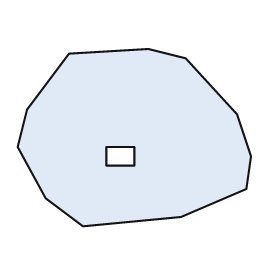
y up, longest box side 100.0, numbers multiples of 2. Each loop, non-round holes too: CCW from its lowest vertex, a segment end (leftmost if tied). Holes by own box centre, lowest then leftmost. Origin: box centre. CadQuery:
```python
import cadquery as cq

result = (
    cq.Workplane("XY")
    .moveTo(-22.0, -38.0)
    .lineTo(20.0, -34.0)
    .lineTo(48.0, -22.0)
    .lineTo(50.0, -8.0)
    .lineTo(44.0, 10.0)
    .lineTo(22.0, 34.0)
    .lineTo(6.0, 38.0)
    .lineTo(-28.0, 36.0)
    .lineTo(-46.0, 12.0)
    .lineTo(-50.0, -4.0)
    .lineTo(-38.0, -26.0)
    .close()
    .moveTo(-12.0, -12.0)
    .lineTo(0.0, -12.0)
    .lineTo(0.0, -4.0)
    .lineTo(-12.0, -4.0)
    .close()
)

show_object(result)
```